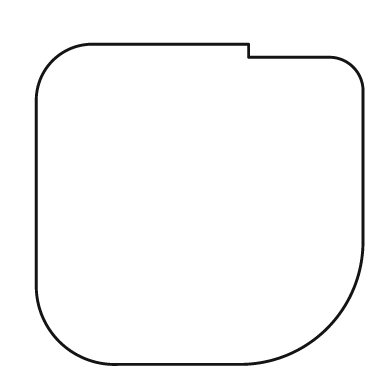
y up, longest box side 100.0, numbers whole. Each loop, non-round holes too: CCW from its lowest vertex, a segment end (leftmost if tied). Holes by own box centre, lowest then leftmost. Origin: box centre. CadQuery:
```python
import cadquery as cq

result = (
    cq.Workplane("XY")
    .moveTo(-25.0, -49.0)
    .lineTo(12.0, -49.0)
    .threePointArc((39.0, -38.0), (50.0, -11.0))
    .lineTo(50.0, 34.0)
    .threePointArc((47.0, 42.0), (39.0, 45.0))
    .lineTo(15.0, 45.0)
    .lineTo(15.0, 49.0)
    .lineTo(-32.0, 49.0)
    .threePointArc((-45.0, 44.0), (-50.0, 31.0))
    .lineTo(-50.0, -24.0)
    .threePointArc((-43.0, -42.0), (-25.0, -49.0))
    .close()
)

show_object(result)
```